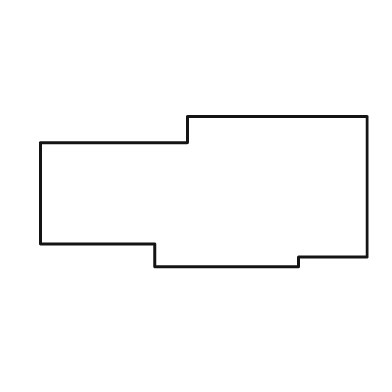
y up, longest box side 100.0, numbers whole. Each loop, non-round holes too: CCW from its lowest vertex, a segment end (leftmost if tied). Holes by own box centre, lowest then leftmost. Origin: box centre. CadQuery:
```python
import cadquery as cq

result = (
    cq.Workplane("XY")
    .moveTo(-15.0, -23.0)
    .lineTo(29.0, -23.0)
    .lineTo(29.0, -20.0)
    .lineTo(50.0, -20.0)
    .lineTo(50.0, 23.0)
    .lineTo(-5.0, 23.0)
    .lineTo(-5.0, 15.0)
    .lineTo(-50.0, 15.0)
    .lineTo(-50.0, -16.0)
    .lineTo(-15.0, -16.0)
    .close()
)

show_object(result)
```